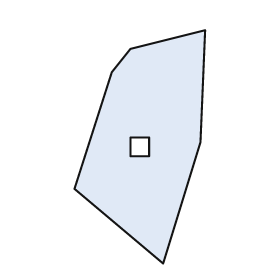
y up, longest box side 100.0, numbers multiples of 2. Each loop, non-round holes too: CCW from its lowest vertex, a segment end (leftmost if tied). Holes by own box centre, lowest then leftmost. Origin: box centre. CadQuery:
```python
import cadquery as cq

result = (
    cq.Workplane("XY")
    .moveTo(10.0, -50.0)
    .lineTo(26.0, 2.0)
    .lineTo(28.0, 50.0)
    .lineTo(-4.0, 42.0)
    .lineTo(-12.0, 32.0)
    .lineTo(-28.0, -18.0)
    .close()
    .moveTo(-4.0, -4.0)
    .lineTo(4.0, -4.0)
    .lineTo(4.0, 4.0)
    .lineTo(-4.0, 4.0)
    .close()
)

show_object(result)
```